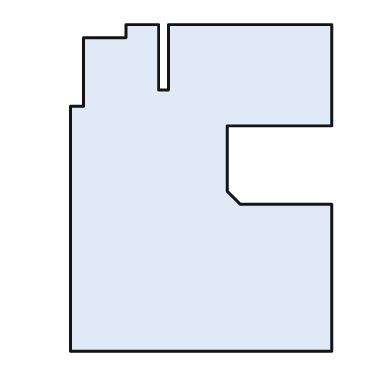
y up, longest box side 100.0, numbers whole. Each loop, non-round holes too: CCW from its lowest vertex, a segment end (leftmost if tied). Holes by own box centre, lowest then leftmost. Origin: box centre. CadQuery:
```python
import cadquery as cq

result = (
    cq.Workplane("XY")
    .moveTo(-40.0, -50.0)
    .lineTo(40.0, -50.0)
    .lineTo(40.0, -5.0)
    .lineTo(12.0, -5.0)
    .lineTo(8.0, -1.0)
    .lineTo(8.0, 19.0)
    .lineTo(40.0, 19.0)
    .lineTo(40.0, 50.0)
    .lineTo(-10.0, 50.0)
    .lineTo(-10.0, 30.0)
    .lineTo(-13.0, 30.0)
    .lineTo(-13.0, 50.0)
    .lineTo(-23.0, 50.0)
    .lineTo(-23.0, 46.0)
    .lineTo(-36.0, 46.0)
    .lineTo(-36.0, 25.0)
    .lineTo(-40.0, 25.0)
    .close()
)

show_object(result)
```